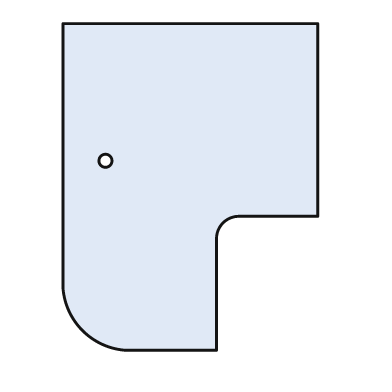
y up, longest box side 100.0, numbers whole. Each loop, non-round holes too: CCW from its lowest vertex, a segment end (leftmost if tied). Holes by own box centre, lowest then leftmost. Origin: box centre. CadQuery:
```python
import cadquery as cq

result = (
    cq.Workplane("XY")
    .moveTo(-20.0, -50.0)
    .lineTo(8.0, -50.0)
    .lineTo(8.0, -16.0)
    .threePointArc((10.0, -11.0), (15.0, -9.0))
    .lineTo(39.0, -9.0)
    .lineTo(39.0, 50.0)
    .lineTo(-39.0, 50.0)
    .lineTo(-39.0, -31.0)
    .threePointArc((-33.0, -44.0), (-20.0, -50.0))
    .close()
    .moveTo(-26.0, 8.0)
    .circle(2.0)
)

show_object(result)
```